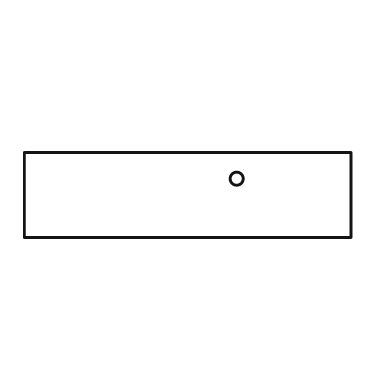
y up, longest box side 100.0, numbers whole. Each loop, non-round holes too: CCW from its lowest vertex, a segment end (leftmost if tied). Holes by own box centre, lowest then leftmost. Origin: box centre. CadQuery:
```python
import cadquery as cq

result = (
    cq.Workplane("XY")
    .moveTo(-50.0, -13.0)
    .lineTo(50.0, -13.0)
    .lineTo(50.0, 13.0)
    .lineTo(-50.0, 13.0)
    .close()
    .moveTo(15.0, 5.0)
    .circle(2.0)
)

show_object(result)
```